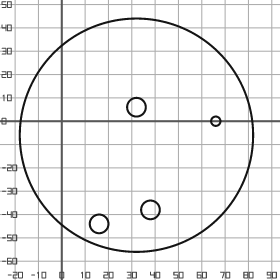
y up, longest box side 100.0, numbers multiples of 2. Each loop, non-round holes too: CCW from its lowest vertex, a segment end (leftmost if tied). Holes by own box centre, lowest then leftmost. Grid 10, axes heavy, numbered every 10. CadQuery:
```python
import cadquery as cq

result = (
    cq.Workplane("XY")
    .moveTo(32.0, -6.0)
    .circle(50.0)
    .moveTo(16.0, -44.0)
    .circle(4.0)
    .moveTo(38.0, -38.0)
    .circle(4.0)
    .moveTo(66.0, 0.0)
    .circle(2.0)
    .moveTo(32.0, 6.0)
    .circle(4.0)
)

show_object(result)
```